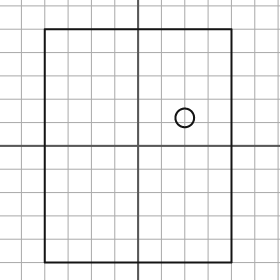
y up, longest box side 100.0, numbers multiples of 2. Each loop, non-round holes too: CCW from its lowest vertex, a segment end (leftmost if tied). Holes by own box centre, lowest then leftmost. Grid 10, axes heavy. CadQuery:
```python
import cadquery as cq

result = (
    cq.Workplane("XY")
    .moveTo(-40.0, -50.0)
    .lineTo(40.0, -50.0)
    .lineTo(40.0, 50.0)
    .lineTo(-40.0, 50.0)
    .close()
    .moveTo(20.0, 12.0)
    .circle(4.0)
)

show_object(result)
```